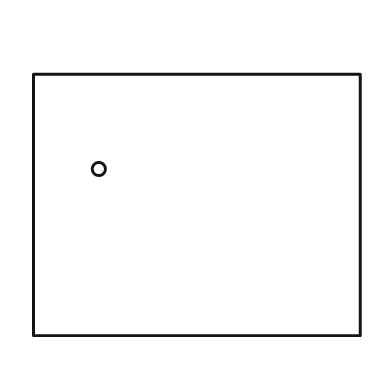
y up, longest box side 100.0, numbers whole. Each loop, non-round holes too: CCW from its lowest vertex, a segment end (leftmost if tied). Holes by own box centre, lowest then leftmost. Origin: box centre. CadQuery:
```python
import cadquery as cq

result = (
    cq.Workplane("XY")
    .moveTo(-50.0, -40.0)
    .lineTo(50.0, -40.0)
    .lineTo(50.0, 40.0)
    .lineTo(-50.0, 40.0)
    .close()
    .moveTo(-30.0, 11.0)
    .circle(2.0)
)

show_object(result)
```